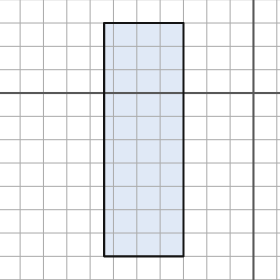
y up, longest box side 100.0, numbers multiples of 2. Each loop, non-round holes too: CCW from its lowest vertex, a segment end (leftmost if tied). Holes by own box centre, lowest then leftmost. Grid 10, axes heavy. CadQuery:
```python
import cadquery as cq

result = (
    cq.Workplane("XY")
    .moveTo(-64.0, -70.0)
    .lineTo(-30.0, -70.0)
    .lineTo(-30.0, 30.0)
    .lineTo(-64.0, 30.0)
    .close()
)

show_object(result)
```